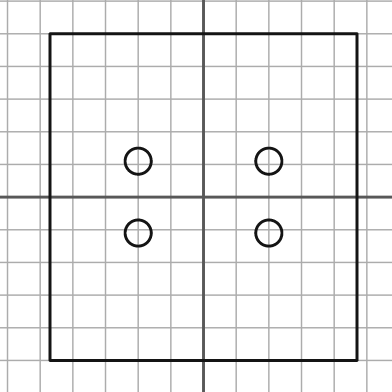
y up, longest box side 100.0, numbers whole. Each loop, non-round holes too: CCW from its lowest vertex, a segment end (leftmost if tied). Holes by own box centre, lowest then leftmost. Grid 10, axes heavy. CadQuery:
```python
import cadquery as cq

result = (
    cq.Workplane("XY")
    .moveTo(-47.0, -50.0)
    .lineTo(47.0, -50.0)
    .lineTo(47.0, 50.0)
    .lineTo(-47.0, 50.0)
    .close()
    .moveTo(-20.0, -11.0)
    .circle(4.0)
    .moveTo(20.0, -11.0)
    .circle(4.0)
    .moveTo(-20.0, 11.0)
    .circle(4.0)
    .moveTo(20.0, 11.0)
    .circle(4.0)
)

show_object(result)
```